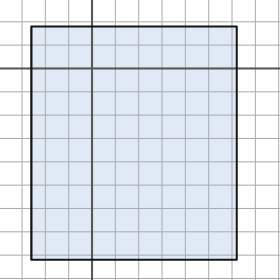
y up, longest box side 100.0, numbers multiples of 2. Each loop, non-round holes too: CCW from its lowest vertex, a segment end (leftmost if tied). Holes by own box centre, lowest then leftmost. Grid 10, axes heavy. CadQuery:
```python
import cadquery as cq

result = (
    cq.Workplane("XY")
    .moveTo(-26.0, -82.0)
    .lineTo(62.0, -82.0)
    .lineTo(62.0, 18.0)
    .lineTo(-26.0, 18.0)
    .close()
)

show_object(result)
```